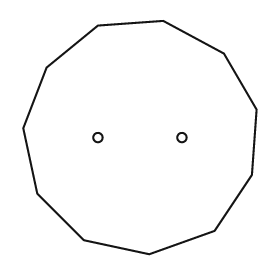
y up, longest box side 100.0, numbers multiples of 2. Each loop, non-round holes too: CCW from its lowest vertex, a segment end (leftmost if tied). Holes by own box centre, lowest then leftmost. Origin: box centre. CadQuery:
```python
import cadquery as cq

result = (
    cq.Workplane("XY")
    .moveTo(4.0, -50.0)
    .lineTo(32.0, -40.0)
    .lineTo(48.0, -16.0)
    .lineTo(50.0, 12.0)
    .lineTo(36.0, 36.0)
    .lineTo(10.0, 50.0)
    .lineTo(-18.0, 48.0)
    .lineTo(-40.0, 30.0)
    .lineTo(-50.0, 4.0)
    .lineTo(-44.0, -24.0)
    .lineTo(-24.0, -44.0)
    .close()
    .moveTo(-18.0, 0.0)
    .circle(2.0)
    .moveTo(18.0, 0.0)
    .circle(2.0)
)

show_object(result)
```